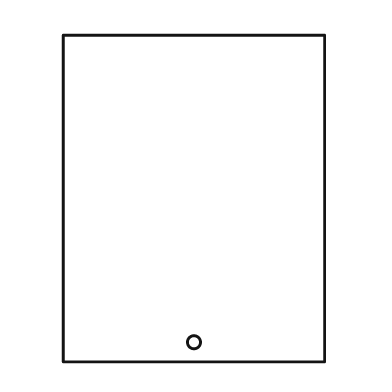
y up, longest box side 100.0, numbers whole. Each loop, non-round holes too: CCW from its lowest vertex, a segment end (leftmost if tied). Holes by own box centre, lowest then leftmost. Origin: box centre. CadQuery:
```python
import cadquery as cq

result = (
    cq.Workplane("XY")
    .moveTo(-40.0, -50.0)
    .lineTo(40.0, -50.0)
    .lineTo(40.0, 50.0)
    .lineTo(-40.0, 50.0)
    .close()
    .moveTo(0.0, -44.0)
    .circle(2.0)
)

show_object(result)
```